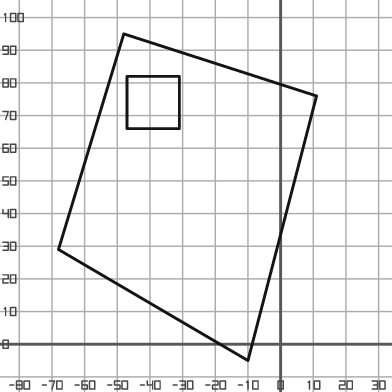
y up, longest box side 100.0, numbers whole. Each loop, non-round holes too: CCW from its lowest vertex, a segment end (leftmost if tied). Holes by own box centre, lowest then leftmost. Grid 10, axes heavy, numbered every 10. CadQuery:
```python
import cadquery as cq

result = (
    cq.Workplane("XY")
    .moveTo(-10.0, -5.0)
    .lineTo(11.0, 76.0)
    .lineTo(-48.0, 95.0)
    .lineTo(-68.0, 29.0)
    .close()
    .moveTo(-47.0, 66.0)
    .lineTo(-31.0, 66.0)
    .lineTo(-31.0, 82.0)
    .lineTo(-47.0, 82.0)
    .close()
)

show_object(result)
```